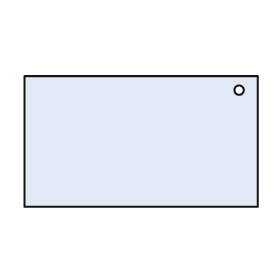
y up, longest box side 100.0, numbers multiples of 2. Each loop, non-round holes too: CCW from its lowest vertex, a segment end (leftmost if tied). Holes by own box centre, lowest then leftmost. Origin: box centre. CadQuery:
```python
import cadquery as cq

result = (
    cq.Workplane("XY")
    .moveTo(-50.0, -28.0)
    .lineTo(50.0, -28.0)
    .lineTo(50.0, 28.0)
    .lineTo(-50.0, 28.0)
    .close()
    .moveTo(42.0, 22.0)
    .circle(2.0)
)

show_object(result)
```